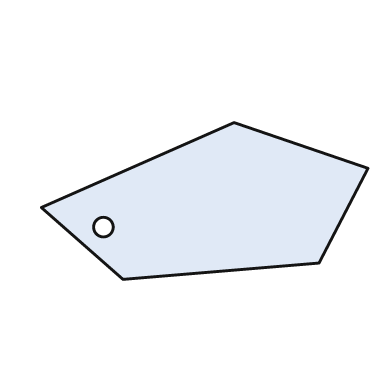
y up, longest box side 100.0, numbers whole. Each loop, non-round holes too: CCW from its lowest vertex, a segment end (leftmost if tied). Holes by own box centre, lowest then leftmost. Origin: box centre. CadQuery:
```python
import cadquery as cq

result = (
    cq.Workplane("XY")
    .moveTo(-25.0, -24.0)
    .lineTo(35.0, -19.0)
    .lineTo(50.0, 10.0)
    .lineTo(9.0, 24.0)
    .lineTo(-50.0, -2.0)
    .close()
    .moveTo(-31.0, -8.0)
    .circle(3.0)
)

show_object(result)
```